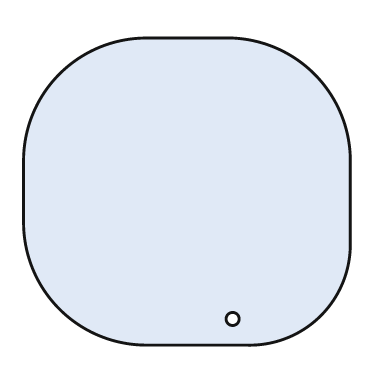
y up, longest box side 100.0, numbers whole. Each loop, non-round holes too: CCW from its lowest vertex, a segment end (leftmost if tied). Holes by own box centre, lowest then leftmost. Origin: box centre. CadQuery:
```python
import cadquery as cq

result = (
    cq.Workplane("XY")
    .moveTo(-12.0, -47.0)
    .lineTo(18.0, -47.0)
    .threePointArc((41.0, -38.0), (50.0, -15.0))
    .lineTo(50.0, 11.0)
    .threePointArc((39.0, 36.0), (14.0, 47.0))
    .lineTo(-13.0, 47.0)
    .threePointArc((-39.0, 36.0), (-50.0, 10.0))
    .lineTo(-50.0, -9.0)
    .threePointArc((-39.0, -36.0), (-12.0, -47.0))
    .close()
    .moveTo(14.0, -39.0)
    .circle(2.0)
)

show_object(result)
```